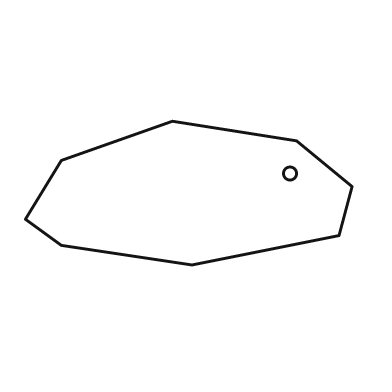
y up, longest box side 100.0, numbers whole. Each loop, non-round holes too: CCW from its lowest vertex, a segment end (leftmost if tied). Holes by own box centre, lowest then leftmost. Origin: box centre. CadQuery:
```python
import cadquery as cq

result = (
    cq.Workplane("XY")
    .moveTo(1.0, -22.0)
    .lineTo(46.0, -13.0)
    .lineTo(50.0, 2.0)
    .lineTo(33.0, 16.0)
    .lineTo(-5.0, 22.0)
    .lineTo(-39.0, 10.0)
    .lineTo(-50.0, -8.0)
    .lineTo(-39.0, -16.0)
    .close()
    .moveTo(31.0, 6.0)
    .circle(2.0)
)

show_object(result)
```